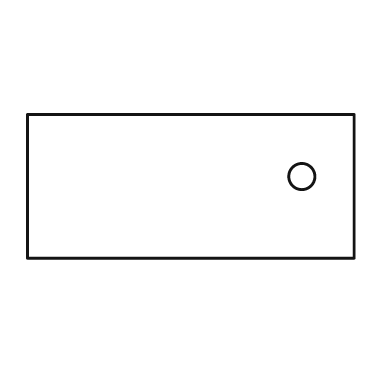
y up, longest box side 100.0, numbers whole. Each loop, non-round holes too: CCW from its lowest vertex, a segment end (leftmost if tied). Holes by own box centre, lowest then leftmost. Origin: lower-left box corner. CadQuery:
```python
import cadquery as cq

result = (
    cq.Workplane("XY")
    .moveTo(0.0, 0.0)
    .lineTo(100.0, 0.0)
    .lineTo(100.0, 44.0)
    .lineTo(0.0, 44.0)
    .close()
    .moveTo(84.0, 25.0)
    .circle(4.0)
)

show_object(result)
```